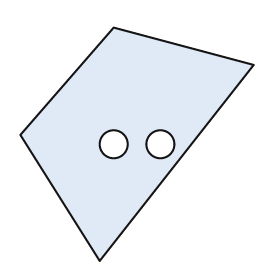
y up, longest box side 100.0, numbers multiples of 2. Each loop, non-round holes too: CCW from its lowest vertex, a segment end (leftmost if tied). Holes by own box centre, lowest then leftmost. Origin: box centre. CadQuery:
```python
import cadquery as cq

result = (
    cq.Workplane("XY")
    .moveTo(-16.0, -50.0)
    .lineTo(50.0, 34.0)
    .lineTo(-10.0, 50.0)
    .lineTo(-50.0, 4.0)
    .close()
    .moveTo(-10.0, 0.0)
    .circle(6.0)
    .moveTo(10.0, 0.0)
    .circle(6.0)
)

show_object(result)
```